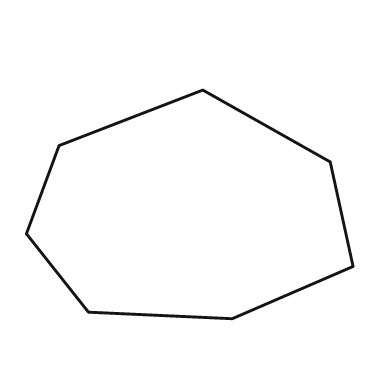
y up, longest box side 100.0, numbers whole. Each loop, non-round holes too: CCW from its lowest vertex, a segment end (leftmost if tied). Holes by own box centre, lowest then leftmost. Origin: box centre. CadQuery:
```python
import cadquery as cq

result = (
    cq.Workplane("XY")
    .moveTo(13.0, -35.0)
    .lineTo(50.0, -19.0)
    .lineTo(43.0, 13.0)
    .lineTo(4.0, 35.0)
    .lineTo(-40.0, 18.0)
    .lineTo(-50.0, -9.0)
    .lineTo(-31.0, -33.0)
    .close()
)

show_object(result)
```